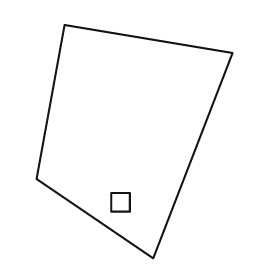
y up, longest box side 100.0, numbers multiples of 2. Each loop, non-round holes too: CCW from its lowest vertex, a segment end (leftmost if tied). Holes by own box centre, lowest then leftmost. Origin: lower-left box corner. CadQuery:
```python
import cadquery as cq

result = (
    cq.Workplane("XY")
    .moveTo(50.0, 0.0)
    .lineTo(84.0, 88.0)
    .lineTo(12.0, 100.0)
    .lineTo(0.0, 34.0)
    .close()
    .moveTo(32.0, 20.0)
    .lineTo(40.0, 20.0)
    .lineTo(40.0, 28.0)
    .lineTo(32.0, 28.0)
    .close()
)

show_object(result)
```